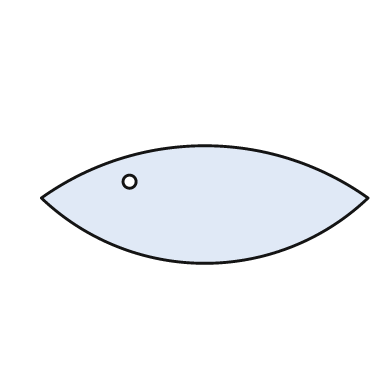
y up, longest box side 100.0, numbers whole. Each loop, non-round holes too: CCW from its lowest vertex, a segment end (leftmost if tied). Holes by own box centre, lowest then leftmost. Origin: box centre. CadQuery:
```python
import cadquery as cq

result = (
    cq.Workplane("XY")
    .moveTo(-50.0, 2.0)
    .threePointArc((0.0, -18.0), (50.0, 2.0))
    .threePointArc((0.0, 18.0), (-50.0, 2.0))
    .close()
    .moveTo(-23.0, 7.0)
    .circle(2.0)
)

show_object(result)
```